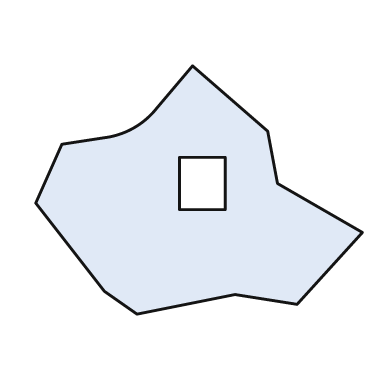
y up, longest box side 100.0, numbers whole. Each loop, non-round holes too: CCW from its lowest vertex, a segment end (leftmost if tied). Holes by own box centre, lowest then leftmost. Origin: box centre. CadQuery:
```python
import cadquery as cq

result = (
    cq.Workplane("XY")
    .moveTo(-19.0, -38.0)
    .lineTo(11.0, -32.0)
    .lineTo(30.0, -35.0)
    .lineTo(50.0, -13.0)
    .lineTo(24.0, 2.0)
    .lineTo(21.0, 18.0)
    .lineTo(-2.0, 38.0)
    .lineTo(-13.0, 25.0)
    .threePointArc((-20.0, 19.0), (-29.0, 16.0))
    .lineTo(-42.0, 14.0)
    .lineTo(-50.0, -4.0)
    .lineTo(-29.0, -31.0)
    .close()
    .moveTo(-6.0, -6.0)
    .lineTo(8.0, -6.0)
    .lineTo(8.0, 10.0)
    .lineTo(-6.0, 10.0)
    .close()
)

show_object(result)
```